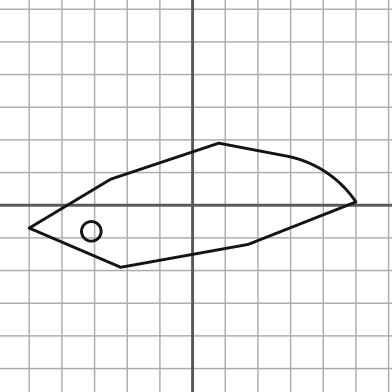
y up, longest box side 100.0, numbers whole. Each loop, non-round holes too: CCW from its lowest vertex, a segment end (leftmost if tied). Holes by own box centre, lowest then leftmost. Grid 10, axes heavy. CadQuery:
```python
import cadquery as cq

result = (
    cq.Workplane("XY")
    .moveTo(-22.0, -19.0)
    .lineTo(17.0, -12.0)
    .lineTo(50.0, 1.0)
    .threePointArc((41.0, 10.0), (29.0, 15.0))
    .lineTo(8.0, 19.0)
    .lineTo(-25.0, 8.0)
    .lineTo(-50.0, -7.0)
    .close()
    .moveTo(-31.0, -8.0)
    .circle(3.0)
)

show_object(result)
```